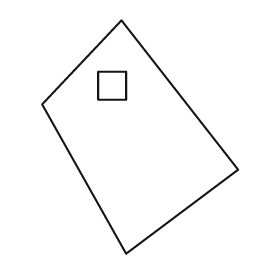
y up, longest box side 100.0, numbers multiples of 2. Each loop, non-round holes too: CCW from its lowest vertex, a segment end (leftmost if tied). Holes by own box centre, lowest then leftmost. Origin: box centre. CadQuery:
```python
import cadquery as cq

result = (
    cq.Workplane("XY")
    .moveTo(-6.0, -50.0)
    .lineTo(42.0, -14.0)
    .lineTo(-8.0, 50.0)
    .lineTo(-42.0, 14.0)
    .close()
    .moveTo(-18.0, 16.0)
    .lineTo(-6.0, 16.0)
    .lineTo(-6.0, 28.0)
    .lineTo(-18.0, 28.0)
    .close()
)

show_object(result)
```